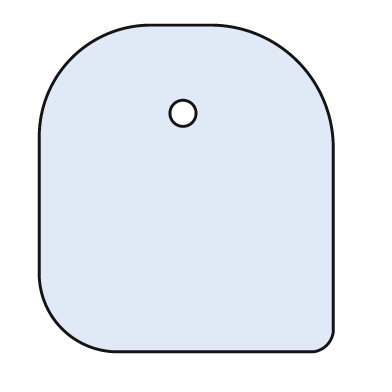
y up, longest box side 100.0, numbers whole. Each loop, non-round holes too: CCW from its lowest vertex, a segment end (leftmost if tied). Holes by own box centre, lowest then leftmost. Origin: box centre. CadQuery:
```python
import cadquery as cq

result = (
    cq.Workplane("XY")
    .moveTo(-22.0, -50.0)
    .lineTo(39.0, -50.0)
    .threePointArc((43.0, -48.0), (45.0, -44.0))
    .lineTo(45.0, 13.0)
    .threePointArc((34.0, 39.0), (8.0, 50.0))
    .lineTo(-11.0, 50.0)
    .threePointArc((-35.0, 40.0), (-45.0, 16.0))
    .lineTo(-45.0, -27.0)
    .threePointArc((-38.0, -43.0), (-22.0, -50.0))
    .close()
    .moveTo(-1.0, 23.0)
    .circle(4.0)
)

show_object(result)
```